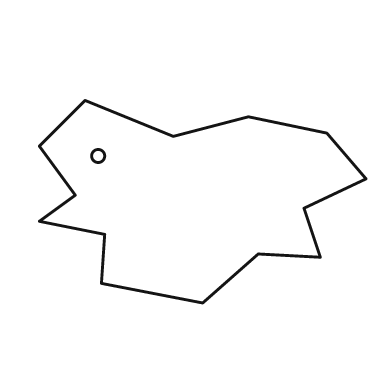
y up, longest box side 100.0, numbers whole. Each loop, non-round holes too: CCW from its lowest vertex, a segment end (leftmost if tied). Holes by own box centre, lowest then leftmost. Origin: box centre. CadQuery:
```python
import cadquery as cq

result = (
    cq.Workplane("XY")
    .moveTo(0.0, -31.0)
    .lineTo(17.0, -16.0)
    .lineTo(36.0, -17.0)
    .lineTo(31.0, -2.0)
    .lineTo(50.0, 7.0)
    .lineTo(38.0, 21.0)
    .lineTo(14.0, 26.0)
    .lineTo(-9.0, 20.0)
    .lineTo(-36.0, 31.0)
    .lineTo(-50.0, 17.0)
    .lineTo(-39.0, 2.0)
    .lineTo(-50.0, -6.0)
    .lineTo(-30.0, -10.0)
    .lineTo(-31.0, -25.0)
    .close()
    .moveTo(-32.0, 14.0)
    .circle(2.0)
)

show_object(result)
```